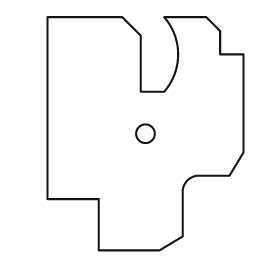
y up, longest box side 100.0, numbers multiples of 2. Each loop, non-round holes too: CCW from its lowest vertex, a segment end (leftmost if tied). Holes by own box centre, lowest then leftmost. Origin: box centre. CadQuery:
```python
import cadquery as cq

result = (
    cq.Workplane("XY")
    .moveTo(-20.0, -50.0)
    .lineTo(6.0, -50.0)
    .lineTo(16.0, -44.0)
    .lineTo(16.0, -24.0)
    .threePointArc((18.0, -20.0), (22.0, -18.0))
    .lineTo(36.0, -18.0)
    .lineTo(42.0, -8.0)
    .lineTo(42.0, 34.0)
    .lineTo(32.0, 34.0)
    .lineTo(32.0, 44.0)
    .lineTo(26.0, 50.0)
    .lineTo(8.0, 50.0)
    .threePointArc((14.0, 34.0), (8.0, 18.0))
    .lineTo(-2.0, 18.0)
    .lineTo(-2.0, 42.0)
    .lineTo(-10.0, 50.0)
    .lineTo(-42.0, 50.0)
    .lineTo(-42.0, -28.0)
    .lineTo(-20.0, -28.0)
    .close()
    .moveTo(0.0, 0.0)
    .circle(4.0)
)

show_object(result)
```